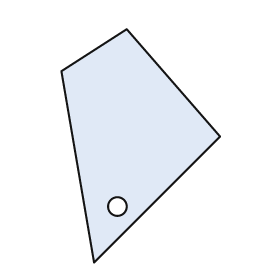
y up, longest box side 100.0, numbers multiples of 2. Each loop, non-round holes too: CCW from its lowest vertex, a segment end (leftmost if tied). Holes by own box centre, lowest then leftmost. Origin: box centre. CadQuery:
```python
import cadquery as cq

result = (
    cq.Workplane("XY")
    .moveTo(-20.0, -50.0)
    .lineTo(34.0, 4.0)
    .lineTo(-6.0, 50.0)
    .lineTo(-34.0, 32.0)
    .close()
    .moveTo(-10.0, -26.0)
    .circle(4.0)
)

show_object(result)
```